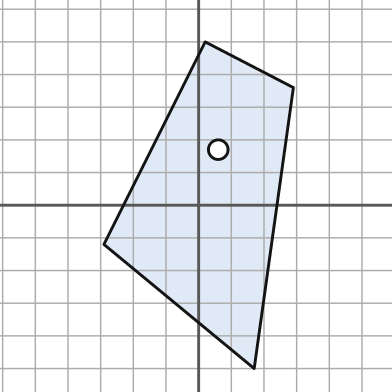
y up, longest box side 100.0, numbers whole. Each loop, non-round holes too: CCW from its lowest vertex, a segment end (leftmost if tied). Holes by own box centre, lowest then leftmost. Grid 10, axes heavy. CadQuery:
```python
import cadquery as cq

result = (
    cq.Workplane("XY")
    .moveTo(17.0, -50.0)
    .lineTo(29.0, 36.0)
    .lineTo(2.0, 50.0)
    .lineTo(-29.0, -12.0)
    .close()
    .moveTo(6.0, 17.0)
    .circle(3.0)
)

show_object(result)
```